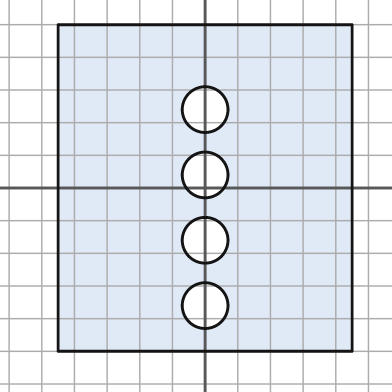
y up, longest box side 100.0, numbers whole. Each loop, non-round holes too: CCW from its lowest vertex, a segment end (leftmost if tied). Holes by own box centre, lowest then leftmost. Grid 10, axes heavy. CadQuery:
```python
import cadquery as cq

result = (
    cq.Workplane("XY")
    .moveTo(-45.0, -50.0)
    .lineTo(45.0, -50.0)
    .lineTo(45.0, 50.0)
    .lineTo(-45.0, 50.0)
    .close()
    .moveTo(0.0, -36.0)
    .circle(7.0)
    .moveTo(0.0, -16.0)
    .circle(7.0)
    .moveTo(0.0, 4.0)
    .circle(7.0)
    .moveTo(0.0, 24.0)
    .circle(7.0)
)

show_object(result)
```